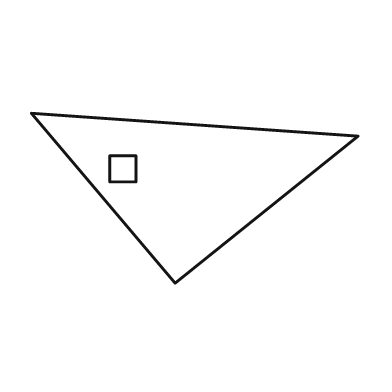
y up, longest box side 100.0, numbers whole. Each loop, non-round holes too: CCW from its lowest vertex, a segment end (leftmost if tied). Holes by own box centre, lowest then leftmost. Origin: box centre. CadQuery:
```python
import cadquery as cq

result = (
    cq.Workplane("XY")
    .moveTo(-6.0, -26.0)
    .lineTo(50.0, 19.0)
    .lineTo(-50.0, 26.0)
    .close()
    .moveTo(-26.0, 5.0)
    .lineTo(-18.0, 5.0)
    .lineTo(-18.0, 13.0)
    .lineTo(-26.0, 13.0)
    .close()
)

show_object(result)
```